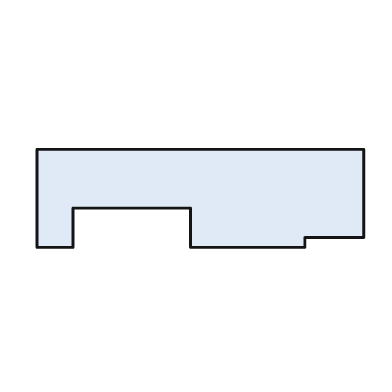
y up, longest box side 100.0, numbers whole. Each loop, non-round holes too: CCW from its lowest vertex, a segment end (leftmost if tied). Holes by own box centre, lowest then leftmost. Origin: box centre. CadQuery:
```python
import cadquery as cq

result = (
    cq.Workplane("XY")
    .moveTo(-50.0, -15.0)
    .lineTo(-39.0, -15.0)
    .lineTo(-39.0, -3.0)
    .lineTo(-3.0, -3.0)
    .lineTo(-3.0, -15.0)
    .lineTo(32.0, -15.0)
    .lineTo(32.0, -12.0)
    .lineTo(50.0, -12.0)
    .lineTo(50.0, 15.0)
    .lineTo(-50.0, 15.0)
    .close()
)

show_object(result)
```